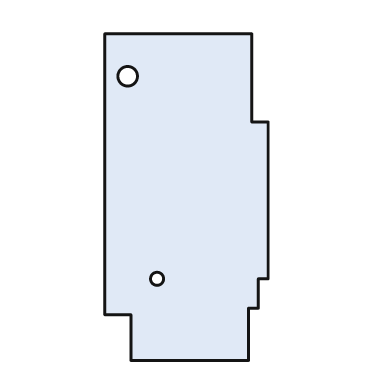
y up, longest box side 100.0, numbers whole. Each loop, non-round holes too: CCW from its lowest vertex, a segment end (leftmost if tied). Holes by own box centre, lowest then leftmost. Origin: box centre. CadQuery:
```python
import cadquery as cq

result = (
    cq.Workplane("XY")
    .moveTo(-17.0, -50.0)
    .lineTo(19.0, -50.0)
    .lineTo(19.0, -34.0)
    .lineTo(22.0, -34.0)
    .lineTo(22.0, -25.0)
    .lineTo(25.0, -25.0)
    .lineTo(25.0, 23.0)
    .lineTo(20.0, 23.0)
    .lineTo(20.0, 50.0)
    .lineTo(-25.0, 50.0)
    .lineTo(-25.0, -36.0)
    .lineTo(-17.0, -36.0)
    .close()
    .moveTo(-9.0, -25.0)
    .circle(2.0)
    .moveTo(-18.0, 37.0)
    .circle(3.0)
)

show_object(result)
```